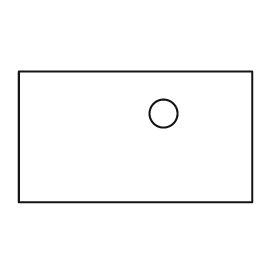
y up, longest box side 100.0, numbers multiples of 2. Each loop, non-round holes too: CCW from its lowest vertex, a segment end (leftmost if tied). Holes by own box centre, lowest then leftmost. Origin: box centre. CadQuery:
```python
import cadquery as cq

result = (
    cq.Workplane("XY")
    .moveTo(-50.0, -28.0)
    .lineTo(50.0, -28.0)
    .lineTo(50.0, 28.0)
    .lineTo(-50.0, 28.0)
    .close()
    .moveTo(12.0, 10.0)
    .circle(6.0)
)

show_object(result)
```